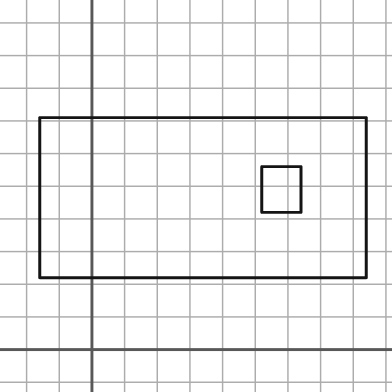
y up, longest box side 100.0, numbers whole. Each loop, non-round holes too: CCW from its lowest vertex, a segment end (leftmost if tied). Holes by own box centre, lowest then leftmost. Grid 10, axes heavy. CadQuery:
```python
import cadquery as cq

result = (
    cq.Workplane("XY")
    .moveTo(-16.0, 22.0)
    .lineTo(84.0, 22.0)
    .lineTo(84.0, 71.0)
    .lineTo(-16.0, 71.0)
    .close()
    .moveTo(52.0, 42.0)
    .lineTo(64.0, 42.0)
    .lineTo(64.0, 56.0)
    .lineTo(52.0, 56.0)
    .close()
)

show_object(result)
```